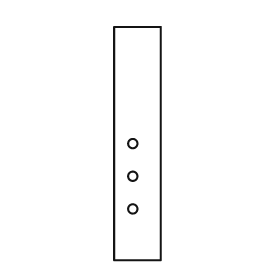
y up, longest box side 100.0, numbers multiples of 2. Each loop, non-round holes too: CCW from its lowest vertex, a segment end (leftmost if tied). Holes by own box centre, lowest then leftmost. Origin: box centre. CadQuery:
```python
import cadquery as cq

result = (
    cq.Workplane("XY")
    .moveTo(-10.0, -50.0)
    .lineTo(10.0, -50.0)
    .lineTo(10.0, 50.0)
    .lineTo(-10.0, 50.0)
    .close()
    .moveTo(-2.0, -28.0)
    .circle(2.0)
    .moveTo(-2.0, -14.0)
    .circle(2.0)
    .moveTo(-2.0, 0.0)
    .circle(2.0)
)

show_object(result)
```